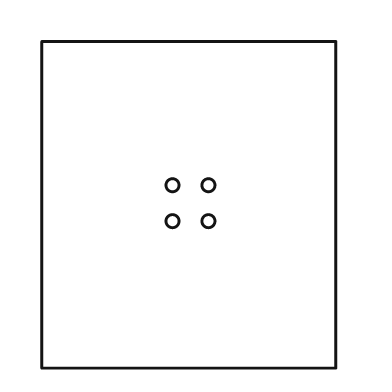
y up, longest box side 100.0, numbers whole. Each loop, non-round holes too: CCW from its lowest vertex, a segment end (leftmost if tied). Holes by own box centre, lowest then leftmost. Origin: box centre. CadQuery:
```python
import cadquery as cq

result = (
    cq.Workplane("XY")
    .moveTo(-45.0, -50.0)
    .lineTo(45.0, -50.0)
    .lineTo(45.0, 50.0)
    .lineTo(-45.0, 50.0)
    .close()
    .moveTo(-5.0, -5.0)
    .circle(2.0)
    .moveTo(6.0, -5.0)
    .circle(2.0)
    .moveTo(-5.0, 6.0)
    .circle(2.0)
    .moveTo(6.0, 6.0)
    .circle(2.0)
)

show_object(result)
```